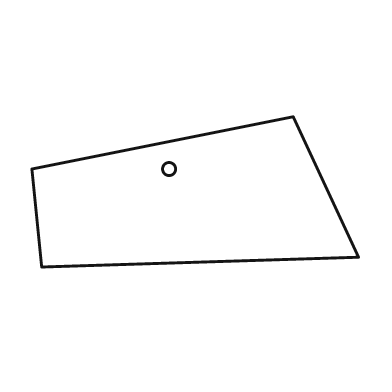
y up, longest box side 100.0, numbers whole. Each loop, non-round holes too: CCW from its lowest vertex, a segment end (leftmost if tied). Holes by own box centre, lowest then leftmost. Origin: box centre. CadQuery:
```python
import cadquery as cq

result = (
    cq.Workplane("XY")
    .moveTo(-47.0, -23.0)
    .lineTo(50.0, -20.0)
    .lineTo(30.0, 23.0)
    .lineTo(-50.0, 7.0)
    .close()
    .moveTo(-8.0, 7.0)
    .circle(2.0)
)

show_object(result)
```